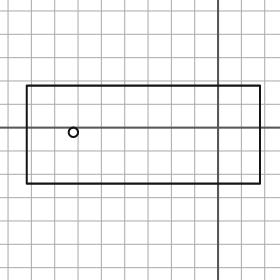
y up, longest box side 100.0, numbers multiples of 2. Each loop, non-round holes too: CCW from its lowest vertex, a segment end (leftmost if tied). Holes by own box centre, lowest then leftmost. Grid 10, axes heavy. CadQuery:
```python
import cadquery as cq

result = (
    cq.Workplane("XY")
    .moveTo(-82.0, -24.0)
    .lineTo(18.0, -24.0)
    .lineTo(18.0, 18.0)
    .lineTo(-82.0, 18.0)
    .close()
    .moveTo(-62.0, -2.0)
    .circle(2.0)
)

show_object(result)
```